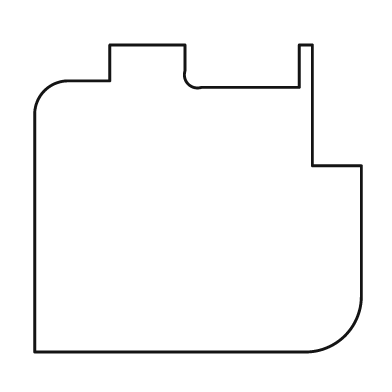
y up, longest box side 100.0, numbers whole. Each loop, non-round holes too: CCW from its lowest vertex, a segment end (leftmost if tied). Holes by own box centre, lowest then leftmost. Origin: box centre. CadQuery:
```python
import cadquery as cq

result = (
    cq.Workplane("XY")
    .moveTo(-50.0, -47.0)
    .lineTo(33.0, -47.0)
    .threePointArc((45.0, -42.0), (50.0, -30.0))
    .lineTo(50.0, 10.0)
    .lineTo(35.0, 10.0)
    .lineTo(35.0, 47.0)
    .lineTo(31.0, 47.0)
    .lineTo(31.0, 34.0)
    .lineTo(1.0, 34.0)
    .threePointArc((-3.0, 35.0), (-4.0, 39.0))
    .lineTo(-4.0, 47.0)
    .lineTo(-27.0, 47.0)
    .lineTo(-27.0, 36.0)
    .lineTo(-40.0, 36.0)
    .threePointArc((-47.0, 33.0), (-50.0, 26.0))
    .close()
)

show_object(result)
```